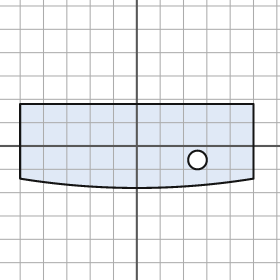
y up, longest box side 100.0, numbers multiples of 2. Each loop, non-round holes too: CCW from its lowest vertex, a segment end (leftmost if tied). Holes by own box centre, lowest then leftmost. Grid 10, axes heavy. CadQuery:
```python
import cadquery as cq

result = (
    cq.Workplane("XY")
    .moveTo(-50.0, -14.0)
    .threePointArc((0.0, -18.0), (50.0, -14.0))
    .lineTo(50.0, 18.0)
    .lineTo(-50.0, 18.0)
    .close()
    .moveTo(26.0, -6.0)
    .circle(4.0)
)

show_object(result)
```